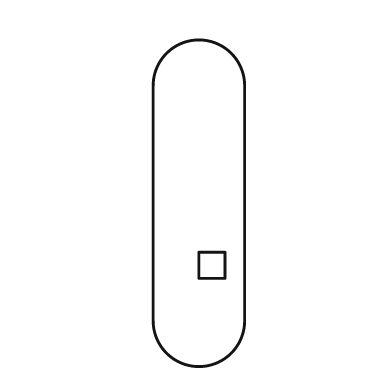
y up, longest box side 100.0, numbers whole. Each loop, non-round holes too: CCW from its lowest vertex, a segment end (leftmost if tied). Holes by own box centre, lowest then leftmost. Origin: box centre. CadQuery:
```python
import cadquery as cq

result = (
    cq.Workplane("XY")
    .moveTo(-14.0, -36.0)
    .threePointArc((0.0, -50.0), (14.0, -36.0))
    .lineTo(14.0, 36.0)
    .threePointArc((0.0, 50.0), (-14.0, 36.0))
    .close()
    .moveTo(0.0, -23.0)
    .lineTo(8.0, -23.0)
    .lineTo(8.0, -15.0)
    .lineTo(0.0, -15.0)
    .close()
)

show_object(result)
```